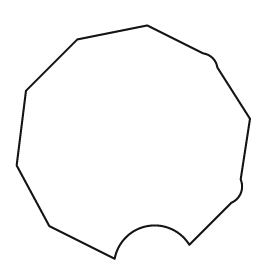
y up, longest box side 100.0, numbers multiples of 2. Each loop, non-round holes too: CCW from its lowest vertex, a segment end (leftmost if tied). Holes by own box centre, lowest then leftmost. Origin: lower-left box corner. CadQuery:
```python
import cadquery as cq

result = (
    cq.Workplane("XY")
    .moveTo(42.0, 0.0)
    .threePointArc((56.0, 14.0), (74.0, 6.0))
    .lineTo(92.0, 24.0)
    .threePointArc((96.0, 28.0), (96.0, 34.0))
    .lineTo(100.0, 60.0)
    .lineTo(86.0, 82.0)
    .threePointArc((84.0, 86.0), (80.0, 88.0))
    .lineTo(56.0, 100.0)
    .lineTo(26.0, 94.0)
    .lineTo(4.0, 72.0)
    .lineTo(0.0, 40.0)
    .lineTo(14.0, 14.0)
    .close()
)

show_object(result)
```